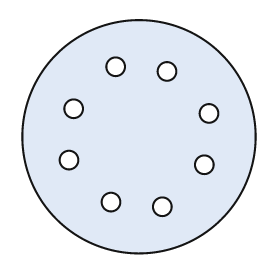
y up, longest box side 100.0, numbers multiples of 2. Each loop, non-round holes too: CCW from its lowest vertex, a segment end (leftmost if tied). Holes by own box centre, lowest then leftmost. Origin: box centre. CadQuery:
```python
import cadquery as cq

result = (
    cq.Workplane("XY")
    .moveTo(0.0, 0.0)
    .circle(50.0)
    .moveTo(10.0, -30.0)
    .circle(4.0)
    .moveTo(-12.0, -28.0)
    .circle(4.0)
    .moveTo(28.0, -12.0)
    .circle(4.0)
    .moveTo(-30.0, -10.0)
    .circle(4.0)
    .moveTo(30.0, 10.0)
    .circle(4.0)
    .moveTo(-28.0, 12.0)
    .circle(4.0)
    .moveTo(12.0, 28.0)
    .circle(4.0)
    .moveTo(-10.0, 30.0)
    .circle(4.0)
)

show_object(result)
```